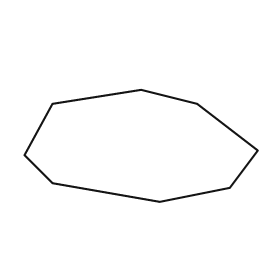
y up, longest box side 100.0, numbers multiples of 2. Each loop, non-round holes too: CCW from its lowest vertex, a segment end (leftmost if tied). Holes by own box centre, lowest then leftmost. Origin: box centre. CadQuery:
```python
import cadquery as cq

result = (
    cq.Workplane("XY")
    .moveTo(8.0, -24.0)
    .lineTo(38.0, -18.0)
    .lineTo(50.0, -2.0)
    .lineTo(24.0, 18.0)
    .lineTo(0.0, 24.0)
    .lineTo(-38.0, 18.0)
    .lineTo(-50.0, -4.0)
    .lineTo(-38.0, -16.0)
    .close()
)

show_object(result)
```